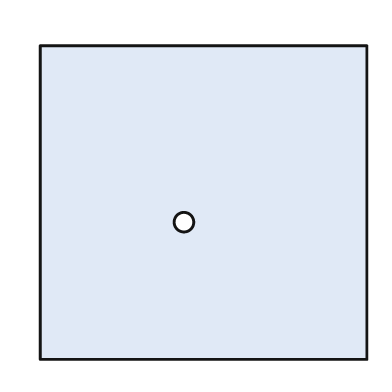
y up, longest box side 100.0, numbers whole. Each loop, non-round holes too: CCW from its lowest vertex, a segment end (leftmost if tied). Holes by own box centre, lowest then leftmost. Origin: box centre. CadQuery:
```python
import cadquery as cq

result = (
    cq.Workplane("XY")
    .moveTo(-50.0, -48.0)
    .lineTo(50.0, -48.0)
    .lineTo(50.0, 48.0)
    .lineTo(-50.0, 48.0)
    .close()
    .moveTo(-6.0, -6.0)
    .circle(3.0)
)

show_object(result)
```